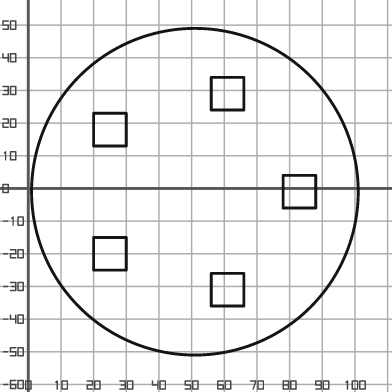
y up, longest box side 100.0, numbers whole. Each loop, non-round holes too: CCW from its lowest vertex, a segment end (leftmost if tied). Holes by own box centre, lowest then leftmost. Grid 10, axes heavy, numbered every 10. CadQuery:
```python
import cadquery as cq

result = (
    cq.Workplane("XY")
    .moveTo(51.0, -1.0)
    .circle(50.0)
    .moveTo(56.0, -36.0)
    .lineTo(66.0, -36.0)
    .lineTo(66.0, -26.0)
    .lineTo(56.0, -26.0)
    .close()
    .moveTo(20.0, -25.0)
    .lineTo(30.0, -25.0)
    .lineTo(30.0, -15.0)
    .lineTo(20.0, -15.0)
    .close()
    .moveTo(78.0, -6.0)
    .lineTo(88.0, -6.0)
    .lineTo(88.0, 4.0)
    .lineTo(78.0, 4.0)
    .close()
    .moveTo(20.0, 13.0)
    .lineTo(30.0, 13.0)
    .lineTo(30.0, 23.0)
    .lineTo(20.0, 23.0)
    .close()
    .moveTo(56.0, 24.0)
    .lineTo(66.0, 24.0)
    .lineTo(66.0, 34.0)
    .lineTo(56.0, 34.0)
    .close()
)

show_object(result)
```